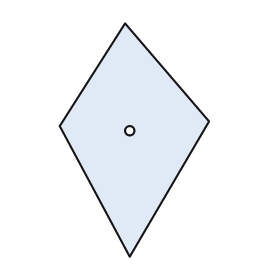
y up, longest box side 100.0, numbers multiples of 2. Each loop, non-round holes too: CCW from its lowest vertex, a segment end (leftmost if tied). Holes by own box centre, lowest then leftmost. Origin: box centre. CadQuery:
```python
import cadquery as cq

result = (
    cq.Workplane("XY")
    .moveTo(-2.0, -50.0)
    .lineTo(32.0, 8.0)
    .lineTo(-4.0, 50.0)
    .lineTo(-32.0, 6.0)
    .close()
    .moveTo(-2.0, 4.0)
    .circle(2.0)
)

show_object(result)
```